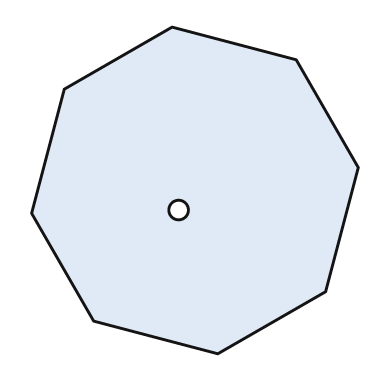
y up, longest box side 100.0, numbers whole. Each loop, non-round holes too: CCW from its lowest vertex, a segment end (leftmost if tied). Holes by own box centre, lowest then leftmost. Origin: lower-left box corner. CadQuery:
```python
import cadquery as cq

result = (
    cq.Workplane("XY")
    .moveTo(57.0, 0.0)
    .lineTo(90.0, 19.0)
    .lineTo(100.0, 57.0)
    .lineTo(81.0, 90.0)
    .lineTo(43.0, 100.0)
    .lineTo(10.0, 81.0)
    .lineTo(0.0, 43.0)
    .lineTo(19.0, 10.0)
    .close()
    .moveTo(45.0, 44.0)
    .circle(3.0)
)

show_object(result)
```